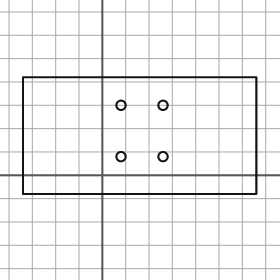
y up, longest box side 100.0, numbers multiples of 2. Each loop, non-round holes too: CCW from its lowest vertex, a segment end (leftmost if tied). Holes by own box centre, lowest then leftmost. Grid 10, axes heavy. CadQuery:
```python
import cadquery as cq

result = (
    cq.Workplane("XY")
    .moveTo(-34.0, -8.0)
    .lineTo(66.0, -8.0)
    .lineTo(66.0, 42.0)
    .lineTo(-34.0, 42.0)
    .close()
    .moveTo(8.0, 8.0)
    .circle(2.0)
    .moveTo(26.0, 8.0)
    .circle(2.0)
    .moveTo(8.0, 30.0)
    .circle(2.0)
    .moveTo(26.0, 30.0)
    .circle(2.0)
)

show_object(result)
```